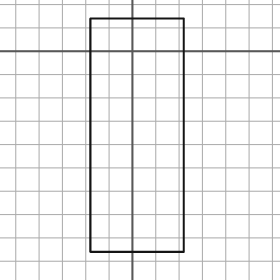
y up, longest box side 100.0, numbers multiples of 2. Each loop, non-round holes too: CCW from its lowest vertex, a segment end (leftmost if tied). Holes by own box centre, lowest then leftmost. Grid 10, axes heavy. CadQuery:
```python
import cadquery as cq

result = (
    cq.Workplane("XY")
    .moveTo(-18.0, -86.0)
    .lineTo(22.0, -86.0)
    .lineTo(22.0, 14.0)
    .lineTo(-18.0, 14.0)
    .close()
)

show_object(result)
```